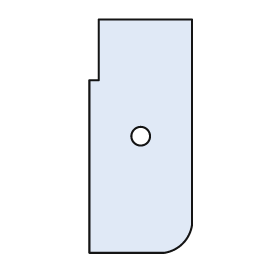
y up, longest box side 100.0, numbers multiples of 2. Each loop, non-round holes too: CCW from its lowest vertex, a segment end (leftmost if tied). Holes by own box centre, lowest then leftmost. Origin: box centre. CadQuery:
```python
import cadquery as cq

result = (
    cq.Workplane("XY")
    .moveTo(-22.0, -50.0)
    .lineTo(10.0, -50.0)
    .threePointArc((18.0, -46.0), (22.0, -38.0))
    .lineTo(22.0, 50.0)
    .lineTo(-18.0, 50.0)
    .lineTo(-18.0, 24.0)
    .lineTo(-22.0, 24.0)
    .close()
    .moveTo(0.0, 0.0)
    .circle(4.0)
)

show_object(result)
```